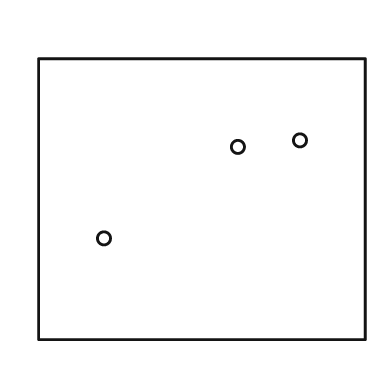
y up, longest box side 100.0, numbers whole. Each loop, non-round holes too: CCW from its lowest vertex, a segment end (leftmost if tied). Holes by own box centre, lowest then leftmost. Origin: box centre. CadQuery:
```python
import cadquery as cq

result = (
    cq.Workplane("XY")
    .moveTo(-50.0, -43.0)
    .lineTo(50.0, -43.0)
    .lineTo(50.0, 43.0)
    .lineTo(-50.0, 43.0)
    .close()
    .moveTo(-30.0, -12.0)
    .circle(2.0)
    .moveTo(11.0, 16.0)
    .circle(2.0)
    .moveTo(30.0, 18.0)
    .circle(2.0)
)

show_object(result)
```